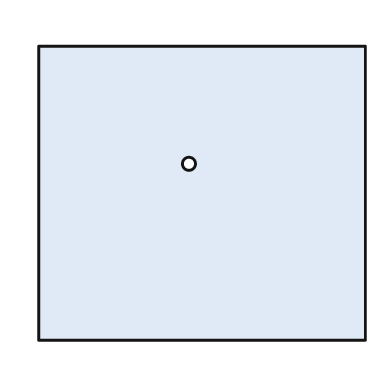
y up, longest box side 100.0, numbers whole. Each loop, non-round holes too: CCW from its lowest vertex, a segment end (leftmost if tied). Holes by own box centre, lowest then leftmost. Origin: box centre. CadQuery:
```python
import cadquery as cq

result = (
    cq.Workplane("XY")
    .moveTo(-50.0, -45.0)
    .lineTo(50.0, -45.0)
    .lineTo(50.0, 45.0)
    .lineTo(-50.0, 45.0)
    .close()
    .moveTo(-4.0, 9.0)
    .circle(2.0)
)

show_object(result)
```